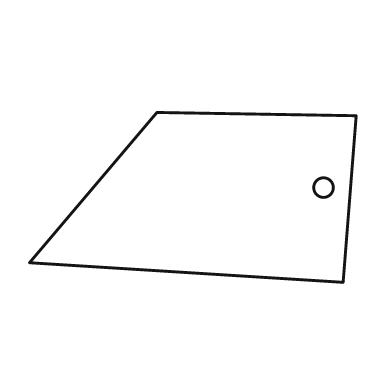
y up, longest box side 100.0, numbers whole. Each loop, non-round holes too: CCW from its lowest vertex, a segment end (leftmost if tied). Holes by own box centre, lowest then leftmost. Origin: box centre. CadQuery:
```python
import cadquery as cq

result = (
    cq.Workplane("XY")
    .moveTo(46.0, -26.0)
    .lineTo(50.0, 25.0)
    .lineTo(-11.0, 26.0)
    .lineTo(-50.0, -20.0)
    .close()
    .moveTo(40.0, 3.0)
    .circle(3.0)
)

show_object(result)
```